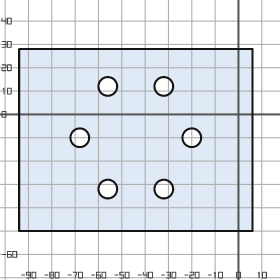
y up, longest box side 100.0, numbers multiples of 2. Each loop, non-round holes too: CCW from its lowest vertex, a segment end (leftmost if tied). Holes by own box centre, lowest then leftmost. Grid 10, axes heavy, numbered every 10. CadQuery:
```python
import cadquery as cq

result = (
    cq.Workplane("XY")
    .moveTo(-94.0, -50.0)
    .lineTo(6.0, -50.0)
    .lineTo(6.0, 28.0)
    .lineTo(-94.0, 28.0)
    .close()
    .moveTo(-56.0, -32.0)
    .circle(4.0)
    .moveTo(-32.0, -32.0)
    .circle(4.0)
    .moveTo(-68.0, -10.0)
    .circle(4.0)
    .moveTo(-20.0, -10.0)
    .circle(4.0)
    .moveTo(-56.0, 12.0)
    .circle(4.0)
    .moveTo(-32.0, 12.0)
    .circle(4.0)
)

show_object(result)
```